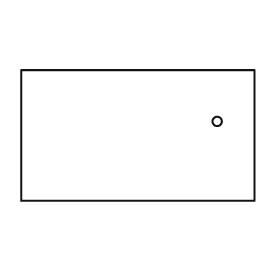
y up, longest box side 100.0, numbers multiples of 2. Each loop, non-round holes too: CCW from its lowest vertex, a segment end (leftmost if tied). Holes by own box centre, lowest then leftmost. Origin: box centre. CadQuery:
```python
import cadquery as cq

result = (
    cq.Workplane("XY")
    .moveTo(-50.0, -28.0)
    .lineTo(50.0, -28.0)
    .lineTo(50.0, 28.0)
    .lineTo(-50.0, 28.0)
    .close()
    .moveTo(34.0, 6.0)
    .circle(2.0)
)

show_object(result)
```